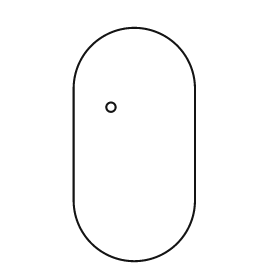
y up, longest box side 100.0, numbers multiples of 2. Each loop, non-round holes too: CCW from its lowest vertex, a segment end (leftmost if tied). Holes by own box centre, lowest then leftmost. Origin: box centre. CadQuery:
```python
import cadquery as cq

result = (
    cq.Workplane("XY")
    .moveTo(-26.0, -24.0)
    .threePointArc((0.0, -50.0), (26.0, -24.0))
    .lineTo(26.0, 24.0)
    .threePointArc((0.0, 50.0), (-26.0, 24.0))
    .close()
    .moveTo(-10.0, 16.0)
    .circle(2.0)
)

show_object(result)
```